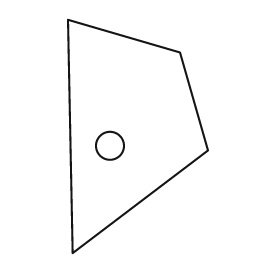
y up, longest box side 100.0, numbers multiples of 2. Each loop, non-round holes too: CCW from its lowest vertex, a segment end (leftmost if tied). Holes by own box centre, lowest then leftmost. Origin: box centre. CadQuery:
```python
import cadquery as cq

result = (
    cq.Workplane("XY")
    .moveTo(-28.0, -50.0)
    .lineTo(30.0, -6.0)
    .lineTo(18.0, 36.0)
    .lineTo(-30.0, 50.0)
    .close()
    .moveTo(-12.0, -4.0)
    .circle(6.0)
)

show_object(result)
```